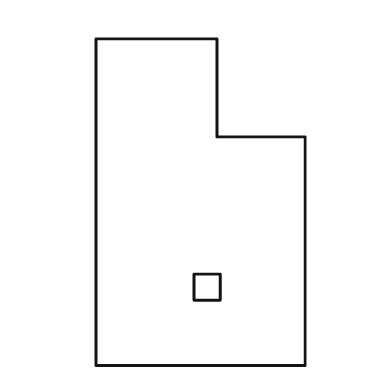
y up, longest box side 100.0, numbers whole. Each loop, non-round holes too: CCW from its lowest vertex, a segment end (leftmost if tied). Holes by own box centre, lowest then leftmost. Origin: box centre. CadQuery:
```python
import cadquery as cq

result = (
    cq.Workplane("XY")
    .moveTo(-32.0, -50.0)
    .lineTo(32.0, -50.0)
    .lineTo(32.0, 20.0)
    .lineTo(5.0, 20.0)
    .lineTo(5.0, 50.0)
    .lineTo(-32.0, 50.0)
    .close()
    .moveTo(-2.0, -30.0)
    .lineTo(6.0, -30.0)
    .lineTo(6.0, -22.0)
    .lineTo(-2.0, -22.0)
    .close()
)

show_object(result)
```